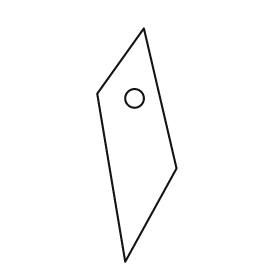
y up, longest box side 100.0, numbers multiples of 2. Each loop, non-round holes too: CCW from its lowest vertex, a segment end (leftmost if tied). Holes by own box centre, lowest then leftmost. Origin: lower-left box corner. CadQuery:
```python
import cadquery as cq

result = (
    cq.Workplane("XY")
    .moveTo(12.0, 0.0)
    .lineTo(34.0, 40.0)
    .lineTo(20.0, 100.0)
    .lineTo(0.0, 72.0)
    .close()
    .moveTo(16.0, 70.0)
    .circle(4.0)
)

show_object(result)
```